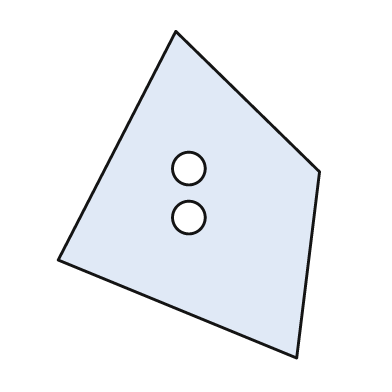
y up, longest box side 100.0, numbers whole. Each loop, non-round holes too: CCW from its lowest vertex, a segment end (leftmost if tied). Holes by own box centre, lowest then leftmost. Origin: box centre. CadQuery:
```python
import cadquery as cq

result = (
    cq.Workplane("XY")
    .moveTo(33.0, -50.0)
    .lineTo(40.0, 7.0)
    .lineTo(-4.0, 50.0)
    .lineTo(-40.0, -20.0)
    .close()
    .moveTo(0.0, -7.0)
    .circle(5.0)
    .moveTo(0.0, 8.0)
    .circle(5.0)
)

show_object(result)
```